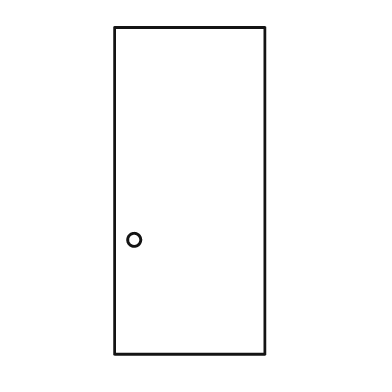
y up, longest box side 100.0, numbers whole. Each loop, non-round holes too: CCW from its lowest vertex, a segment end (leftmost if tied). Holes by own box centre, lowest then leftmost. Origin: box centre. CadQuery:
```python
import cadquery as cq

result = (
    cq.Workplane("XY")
    .moveTo(-23.0, -50.0)
    .lineTo(23.0, -50.0)
    .lineTo(23.0, 50.0)
    .lineTo(-23.0, 50.0)
    .close()
    .moveTo(-17.0, -15.0)
    .circle(2.0)
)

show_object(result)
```